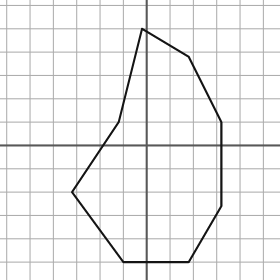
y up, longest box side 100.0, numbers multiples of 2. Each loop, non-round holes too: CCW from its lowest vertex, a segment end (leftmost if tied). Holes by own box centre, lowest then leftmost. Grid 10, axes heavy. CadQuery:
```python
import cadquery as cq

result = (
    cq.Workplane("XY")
    .moveTo(-10.0, -50.0)
    .lineTo(18.0, -50.0)
    .lineTo(32.0, -26.0)
    .lineTo(32.0, 10.0)
    .lineTo(18.0, 38.0)
    .lineTo(-2.0, 50.0)
    .lineTo(-12.0, 10.0)
    .lineTo(-32.0, -20.0)
    .close()
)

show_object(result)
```